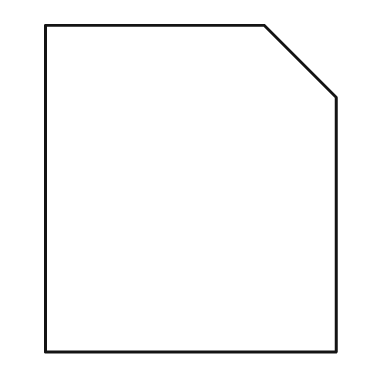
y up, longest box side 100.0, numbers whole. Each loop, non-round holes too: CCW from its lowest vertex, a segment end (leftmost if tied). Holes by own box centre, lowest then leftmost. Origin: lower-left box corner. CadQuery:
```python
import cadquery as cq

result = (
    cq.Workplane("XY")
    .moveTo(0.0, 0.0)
    .lineTo(89.0, 0.0)
    .lineTo(89.0, 78.0)
    .lineTo(67.0, 100.0)
    .lineTo(0.0, 100.0)
    .close()
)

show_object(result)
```